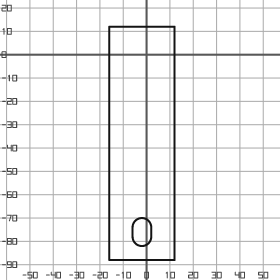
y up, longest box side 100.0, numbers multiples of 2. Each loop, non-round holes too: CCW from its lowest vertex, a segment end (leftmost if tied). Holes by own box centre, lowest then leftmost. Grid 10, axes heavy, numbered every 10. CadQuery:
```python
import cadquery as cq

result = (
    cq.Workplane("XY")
    .moveTo(-16.0, -88.0)
    .lineTo(12.0, -88.0)
    .lineTo(12.0, 12.0)
    .lineTo(-16.0, 12.0)
    .close()
    .moveTo(-6.0, -78.0)
    .threePointArc((-2.0, -82.0), (2.0, -78.0))
    .lineTo(2.0, -74.0)
    .threePointArc((-2.0, -70.0), (-6.0, -74.0))
    .close()
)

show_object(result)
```